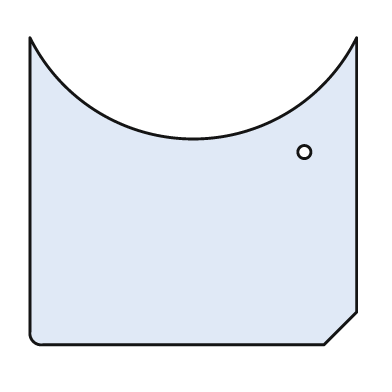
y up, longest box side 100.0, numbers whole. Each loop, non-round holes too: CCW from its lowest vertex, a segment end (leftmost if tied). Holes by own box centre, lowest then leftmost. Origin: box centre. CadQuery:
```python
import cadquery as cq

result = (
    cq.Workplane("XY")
    .moveTo(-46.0, -47.0)
    .lineTo(40.0, -47.0)
    .lineTo(50.0, -37.0)
    .lineTo(50.0, 47.0)
    .threePointArc((0.0, 16.0), (-50.0, 47.0))
    .lineTo(-50.0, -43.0)
    .threePointArc((-49.0, -46.0), (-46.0, -47.0))
    .close()
    .moveTo(34.0, 12.0)
    .circle(2.0)
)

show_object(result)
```